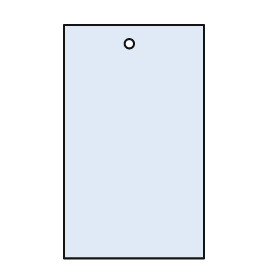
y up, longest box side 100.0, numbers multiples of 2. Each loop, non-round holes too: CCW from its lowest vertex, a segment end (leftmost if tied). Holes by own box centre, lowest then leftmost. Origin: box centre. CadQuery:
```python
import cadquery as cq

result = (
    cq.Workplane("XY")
    .moveTo(-30.0, -50.0)
    .lineTo(30.0, -50.0)
    .lineTo(30.0, 50.0)
    .lineTo(-30.0, 50.0)
    .close()
    .moveTo(-2.0, 42.0)
    .circle(2.0)
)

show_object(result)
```